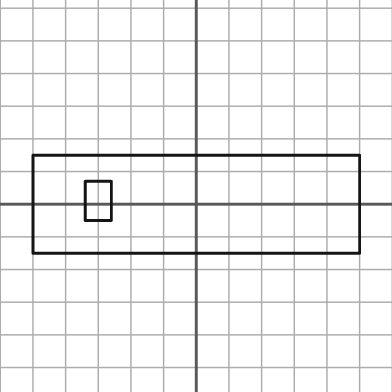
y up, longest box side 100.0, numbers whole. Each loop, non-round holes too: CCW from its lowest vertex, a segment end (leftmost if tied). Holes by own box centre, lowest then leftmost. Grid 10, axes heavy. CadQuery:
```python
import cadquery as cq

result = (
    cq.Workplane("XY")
    .moveTo(-50.0, -15.0)
    .lineTo(50.0, -15.0)
    .lineTo(50.0, 15.0)
    .lineTo(-50.0, 15.0)
    .close()
    .moveTo(-34.0, -5.0)
    .lineTo(-26.0, -5.0)
    .lineTo(-26.0, 7.0)
    .lineTo(-34.0, 7.0)
    .close()
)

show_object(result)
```